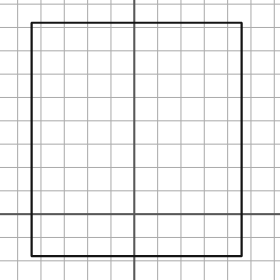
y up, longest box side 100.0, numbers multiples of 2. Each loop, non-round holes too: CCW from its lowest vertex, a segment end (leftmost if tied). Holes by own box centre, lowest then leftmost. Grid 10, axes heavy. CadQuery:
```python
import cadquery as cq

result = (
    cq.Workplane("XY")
    .moveTo(-44.0, -18.0)
    .lineTo(46.0, -18.0)
    .lineTo(46.0, 82.0)
    .lineTo(-44.0, 82.0)
    .close()
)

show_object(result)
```